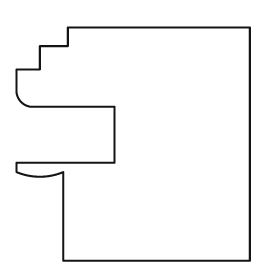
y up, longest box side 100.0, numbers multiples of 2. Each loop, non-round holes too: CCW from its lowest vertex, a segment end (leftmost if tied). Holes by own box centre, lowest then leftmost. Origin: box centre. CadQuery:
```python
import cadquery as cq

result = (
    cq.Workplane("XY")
    .moveTo(-30.0, -50.0)
    .lineTo(50.0, -50.0)
    .lineTo(50.0, 50.0)
    .lineTo(-28.0, 50.0)
    .lineTo(-28.0, 42.0)
    .lineTo(-40.0, 42.0)
    .lineTo(-40.0, 32.0)
    .lineTo(-50.0, 32.0)
    .lineTo(-50.0, 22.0)
    .threePointArc((-48.0, 18.0), (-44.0, 16.0))
    .lineTo(-8.0, 16.0)
    .lineTo(-8.0, -8.0)
    .lineTo(-50.0, -8.0)
    .lineTo(-50.0, -12.0)
    .threePointArc((-40.0, -14.0), (-30.0, -12.0))
    .close()
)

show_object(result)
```